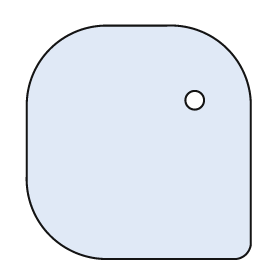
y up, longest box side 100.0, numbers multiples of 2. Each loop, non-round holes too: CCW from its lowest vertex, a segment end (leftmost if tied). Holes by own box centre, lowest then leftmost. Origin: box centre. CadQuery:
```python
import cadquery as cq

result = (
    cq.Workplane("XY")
    .moveTo(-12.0, -50.0)
    .lineTo(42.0, -50.0)
    .threePointArc((46.0, -48.0), (48.0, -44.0))
    .lineTo(48.0, 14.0)
    .threePointArc((38.0, 40.0), (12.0, 50.0))
    .lineTo(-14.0, 50.0)
    .threePointArc((-38.0, 40.0), (-48.0, 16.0))
    .lineTo(-48.0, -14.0)
    .threePointArc((-38.0, -40.0), (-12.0, -50.0))
    .close()
    .moveTo(24.0, 18.0)
    .circle(4.0)
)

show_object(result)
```